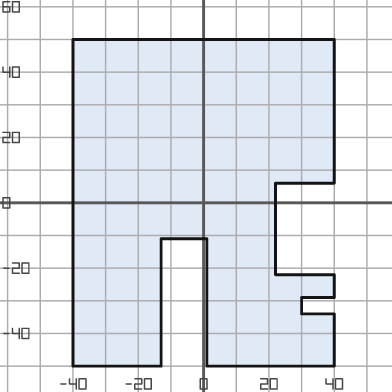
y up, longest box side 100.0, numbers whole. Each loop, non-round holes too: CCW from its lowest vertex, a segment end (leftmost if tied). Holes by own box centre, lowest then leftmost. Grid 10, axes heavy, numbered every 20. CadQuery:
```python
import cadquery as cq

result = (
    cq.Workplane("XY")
    .moveTo(-40.0, -50.0)
    .lineTo(-13.0, -50.0)
    .lineTo(-13.0, -11.0)
    .lineTo(1.0, -11.0)
    .lineTo(1.0, -50.0)
    .lineTo(40.0, -50.0)
    .lineTo(40.0, -34.0)
    .lineTo(30.0, -34.0)
    .lineTo(30.0, -29.0)
    .lineTo(40.0, -29.0)
    .lineTo(40.0, -22.0)
    .lineTo(22.0, -22.0)
    .lineTo(22.0, 6.0)
    .lineTo(40.0, 6.0)
    .lineTo(40.0, 50.0)
    .lineTo(-40.0, 50.0)
    .close()
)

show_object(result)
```